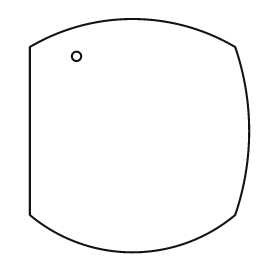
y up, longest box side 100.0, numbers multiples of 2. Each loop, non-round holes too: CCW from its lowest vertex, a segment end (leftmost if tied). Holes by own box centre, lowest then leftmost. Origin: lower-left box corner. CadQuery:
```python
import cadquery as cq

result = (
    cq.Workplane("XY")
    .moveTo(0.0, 16.0)
    .threePointArc((44.0, 0.0), (88.0, 16.0))
    .threePointArc((94.0, 52.0), (88.0, 88.0))
    .threePointArc((44.0, 100.0), (0.0, 88.0))
    .close()
    .moveTo(20.0, 84.0)
    .circle(2.0)
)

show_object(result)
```